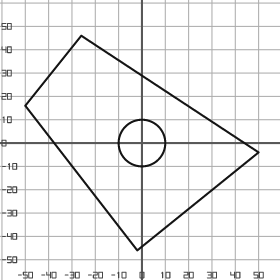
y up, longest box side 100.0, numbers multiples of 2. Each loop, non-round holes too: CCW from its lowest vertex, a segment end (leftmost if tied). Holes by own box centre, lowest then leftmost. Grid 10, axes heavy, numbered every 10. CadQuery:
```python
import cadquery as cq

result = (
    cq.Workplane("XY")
    .moveTo(-2.0, -46.0)
    .lineTo(50.0, -4.0)
    .lineTo(-26.0, 46.0)
    .lineTo(-50.0, 16.0)
    .close()
    .moveTo(0.0, 0.0)
    .circle(10.0)
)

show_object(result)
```